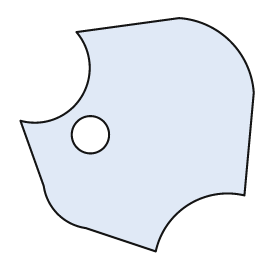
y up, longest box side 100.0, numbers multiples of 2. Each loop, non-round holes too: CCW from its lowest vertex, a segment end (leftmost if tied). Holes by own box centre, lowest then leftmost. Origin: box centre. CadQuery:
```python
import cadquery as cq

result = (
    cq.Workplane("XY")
    .moveTo(8.0, -50.0)
    .threePointArc((22.0, -30.0), (46.0, -26.0))
    .lineTo(50.0, 18.0)
    .threePointArc((40.0, 40.0), (18.0, 50.0))
    .lineTo(-26.0, 44.0)
    .threePointArc((-24.0, 16.0), (-50.0, 6.0))
    .lineTo(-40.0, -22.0)
    .threePointArc((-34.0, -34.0), (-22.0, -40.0))
    .close()
    .moveTo(-20.0, 0.0)
    .circle(8.0)
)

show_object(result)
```